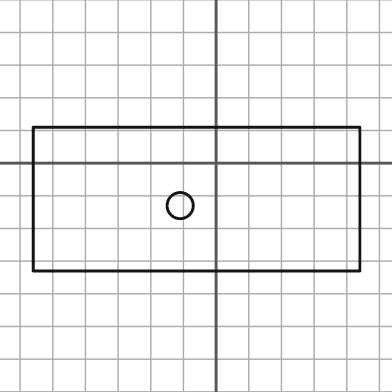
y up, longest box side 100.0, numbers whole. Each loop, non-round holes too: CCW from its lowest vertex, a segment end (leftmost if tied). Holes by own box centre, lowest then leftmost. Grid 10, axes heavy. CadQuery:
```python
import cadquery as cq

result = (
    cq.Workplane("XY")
    .moveTo(-56.0, -33.0)
    .lineTo(44.0, -33.0)
    .lineTo(44.0, 11.0)
    .lineTo(-56.0, 11.0)
    .close()
    .moveTo(-11.0, -13.0)
    .circle(4.0)
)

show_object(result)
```